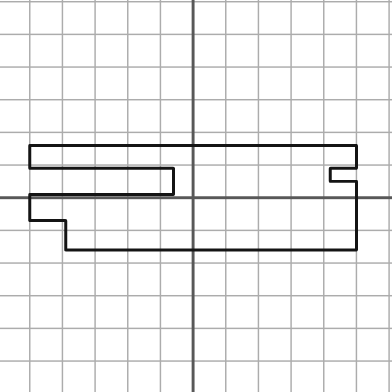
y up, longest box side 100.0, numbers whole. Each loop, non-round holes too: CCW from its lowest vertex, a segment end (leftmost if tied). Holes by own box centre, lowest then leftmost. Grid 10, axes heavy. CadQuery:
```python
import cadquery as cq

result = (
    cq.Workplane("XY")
    .moveTo(-39.0, -16.0)
    .lineTo(50.0, -16.0)
    .lineTo(50.0, 5.0)
    .lineTo(42.0, 5.0)
    .lineTo(42.0, 9.0)
    .lineTo(50.0, 9.0)
    .lineTo(50.0, 16.0)
    .lineTo(-50.0, 16.0)
    .lineTo(-50.0, 9.0)
    .lineTo(-6.0, 9.0)
    .lineTo(-6.0, 1.0)
    .lineTo(-50.0, 1.0)
    .lineTo(-50.0, -7.0)
    .lineTo(-39.0, -7.0)
    .close()
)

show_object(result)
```